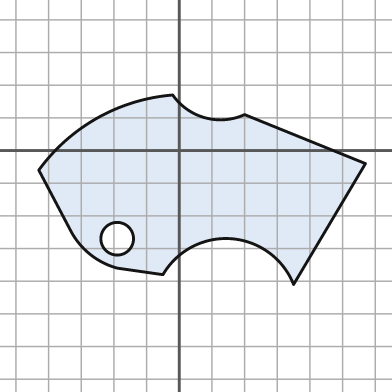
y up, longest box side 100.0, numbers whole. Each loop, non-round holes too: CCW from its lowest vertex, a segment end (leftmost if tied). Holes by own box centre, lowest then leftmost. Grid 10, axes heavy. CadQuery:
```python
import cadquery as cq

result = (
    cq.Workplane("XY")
    .moveTo(35.0, -41.0)
    .lineTo(57.0, -4.0)
    .lineTo(20.0, 11.0)
    .threePointArc((8.0, 10.0), (-2.0, 17.0))
    .threePointArc((-25.0, 10.0), (-43.0, -6.0))
    .lineTo(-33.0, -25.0)
    .threePointArc((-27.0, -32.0), (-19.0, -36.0))
    .lineTo(-5.0, -38.0)
    .threePointArc((16.0, -27.0), (35.0, -41.0))
    .close()
    .moveTo(-19.0, -27.0)
    .circle(5.0)
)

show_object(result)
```